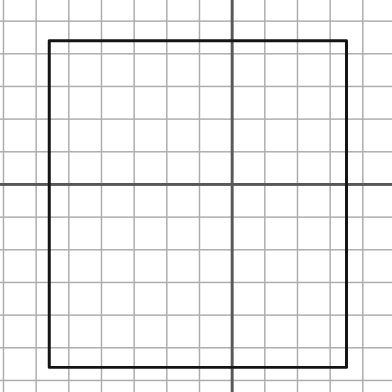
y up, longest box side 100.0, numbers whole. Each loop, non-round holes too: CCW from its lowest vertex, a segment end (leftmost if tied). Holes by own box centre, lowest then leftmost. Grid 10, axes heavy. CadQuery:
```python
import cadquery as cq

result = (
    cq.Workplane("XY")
    .moveTo(-56.0, -56.0)
    .lineTo(35.0, -56.0)
    .lineTo(35.0, 44.0)
    .lineTo(-56.0, 44.0)
    .close()
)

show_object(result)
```